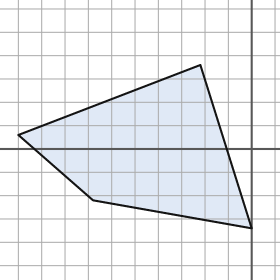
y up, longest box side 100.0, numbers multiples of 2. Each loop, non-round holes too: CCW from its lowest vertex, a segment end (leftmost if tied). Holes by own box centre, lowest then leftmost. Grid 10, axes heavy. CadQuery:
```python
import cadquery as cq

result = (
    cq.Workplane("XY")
    .moveTo(0.0, -34.0)
    .lineTo(-22.0, 36.0)
    .lineTo(-100.0, 6.0)
    .lineTo(-68.0, -22.0)
    .close()
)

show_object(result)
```